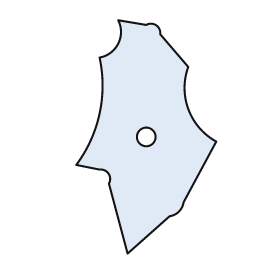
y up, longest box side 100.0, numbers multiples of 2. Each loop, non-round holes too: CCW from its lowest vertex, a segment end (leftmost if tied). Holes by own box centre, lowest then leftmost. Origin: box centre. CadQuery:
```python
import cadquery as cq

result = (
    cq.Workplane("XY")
    .moveTo(-8.0, -50.0)
    .lineTo(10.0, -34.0)
    .threePointArc((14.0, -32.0), (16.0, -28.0))
    .lineTo(30.0, -2.0)
    .threePointArc((18.0, 12.0), (18.0, 30.0))
    .lineTo(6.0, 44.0)
    .threePointArc((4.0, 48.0), (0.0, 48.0))
    .lineTo(-12.0, 50.0)
    .threePointArc((-12.0, 40.0), (-20.0, 34.0))
    .threePointArc((-20.0, 10.0), (-30.0, -12.0))
    .lineTo(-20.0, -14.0)
    .threePointArc((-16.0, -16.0), (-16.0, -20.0))
    .close()
    .moveTo(0.0, 0.0)
    .circle(4.0)
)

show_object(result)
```